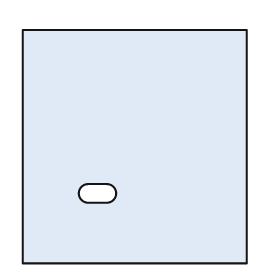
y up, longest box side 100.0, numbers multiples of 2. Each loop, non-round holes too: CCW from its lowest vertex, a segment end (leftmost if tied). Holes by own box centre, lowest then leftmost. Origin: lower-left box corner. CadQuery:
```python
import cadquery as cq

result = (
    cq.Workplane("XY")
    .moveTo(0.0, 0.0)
    .lineTo(96.0, 0.0)
    .lineTo(96.0, 100.0)
    .lineTo(0.0, 100.0)
    .close()
    .moveTo(28.0, 26.0)
    .lineTo(36.0, 26.0)
    .threePointArc((40.0, 30.0), (36.0, 34.0))
    .lineTo(28.0, 34.0)
    .threePointArc((24.0, 30.0), (28.0, 26.0))
    .close()
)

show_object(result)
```